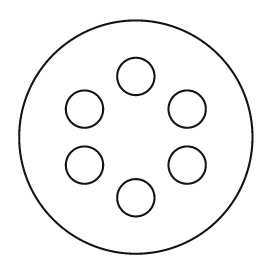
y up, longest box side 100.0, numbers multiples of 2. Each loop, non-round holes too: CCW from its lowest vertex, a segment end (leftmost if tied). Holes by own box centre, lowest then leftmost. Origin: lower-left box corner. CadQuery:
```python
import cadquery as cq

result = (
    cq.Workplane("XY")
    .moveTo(50.0, 50.0)
    .circle(50.0)
    .moveTo(50.0, 24.0)
    .circle(8.0)
    .moveTo(28.0, 38.0)
    .circle(8.0)
    .moveTo(72.0, 38.0)
    .circle(8.0)
    .moveTo(28.0, 62.0)
    .circle(8.0)
    .moveTo(72.0, 62.0)
    .circle(8.0)
    .moveTo(50.0, 76.0)
    .circle(8.0)
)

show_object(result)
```